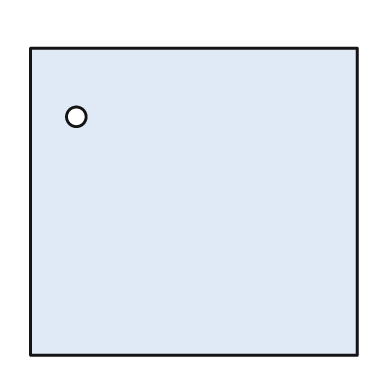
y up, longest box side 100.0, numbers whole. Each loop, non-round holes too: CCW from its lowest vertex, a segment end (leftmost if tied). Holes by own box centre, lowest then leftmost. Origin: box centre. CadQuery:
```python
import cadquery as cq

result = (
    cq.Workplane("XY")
    .moveTo(-50.0, -47.0)
    .lineTo(50.0, -47.0)
    .lineTo(50.0, 47.0)
    .lineTo(-50.0, 47.0)
    .close()
    .moveTo(-36.0, 26.0)
    .circle(3.0)
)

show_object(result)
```